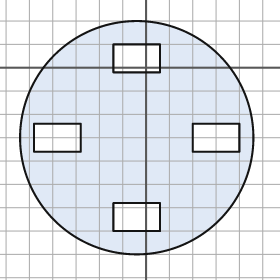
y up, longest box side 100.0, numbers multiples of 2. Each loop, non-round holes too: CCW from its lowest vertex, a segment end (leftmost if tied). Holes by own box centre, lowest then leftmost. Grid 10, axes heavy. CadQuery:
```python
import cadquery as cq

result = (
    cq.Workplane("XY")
    .moveTo(-4.0, -30.0)
    .circle(50.0)
    .moveTo(-14.0, -70.0)
    .lineTo(6.0, -70.0)
    .lineTo(6.0, -58.0)
    .lineTo(-14.0, -58.0)
    .close()
    .moveTo(-48.0, -36.0)
    .lineTo(-28.0, -36.0)
    .lineTo(-28.0, -24.0)
    .lineTo(-48.0, -24.0)
    .close()
    .moveTo(20.0, -36.0)
    .lineTo(40.0, -36.0)
    .lineTo(40.0, -24.0)
    .lineTo(20.0, -24.0)
    .close()
    .moveTo(-14.0, -2.0)
    .lineTo(6.0, -2.0)
    .lineTo(6.0, 10.0)
    .lineTo(-14.0, 10.0)
    .close()
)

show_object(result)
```